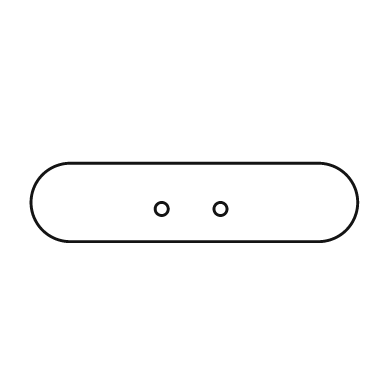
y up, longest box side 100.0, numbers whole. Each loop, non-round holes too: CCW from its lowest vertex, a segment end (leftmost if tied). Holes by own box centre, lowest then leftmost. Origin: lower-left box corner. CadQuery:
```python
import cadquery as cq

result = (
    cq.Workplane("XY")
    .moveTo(12.0, 0.0)
    .lineTo(88.0, 0.0)
    .threePointArc((100.0, 12.0), (88.0, 24.0))
    .lineTo(12.0, 24.0)
    .threePointArc((0.0, 12.0), (12.0, 0.0))
    .close()
    .moveTo(40.0, 10.0)
    .circle(2.0)
    .moveTo(58.0, 10.0)
    .circle(2.0)
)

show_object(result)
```